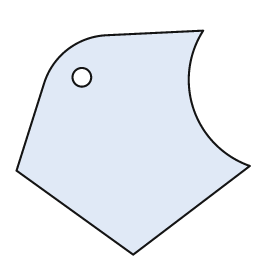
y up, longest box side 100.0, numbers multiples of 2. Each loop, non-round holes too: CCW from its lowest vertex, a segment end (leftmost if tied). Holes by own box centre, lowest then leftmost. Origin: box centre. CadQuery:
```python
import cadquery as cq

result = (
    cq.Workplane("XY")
    .moveTo(0.0, -48.0)
    .lineTo(50.0, -10.0)
    .threePointArc((26.0, 14.0), (30.0, 48.0))
    .lineTo(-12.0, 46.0)
    .threePointArc((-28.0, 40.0), (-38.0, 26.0))
    .lineTo(-50.0, -12.0)
    .close()
    .moveTo(-22.0, 28.0)
    .circle(4.0)
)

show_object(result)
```